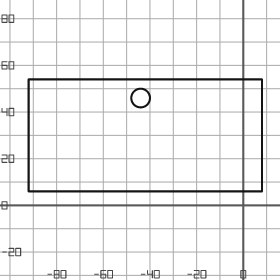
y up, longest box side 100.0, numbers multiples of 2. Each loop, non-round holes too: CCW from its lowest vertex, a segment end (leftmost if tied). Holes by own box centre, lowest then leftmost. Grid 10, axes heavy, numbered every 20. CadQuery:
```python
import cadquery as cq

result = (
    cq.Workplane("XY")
    .moveTo(-92.0, 6.0)
    .lineTo(8.0, 6.0)
    .lineTo(8.0, 54.0)
    .lineTo(-92.0, 54.0)
    .close()
    .moveTo(-44.0, 46.0)
    .circle(4.0)
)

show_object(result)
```